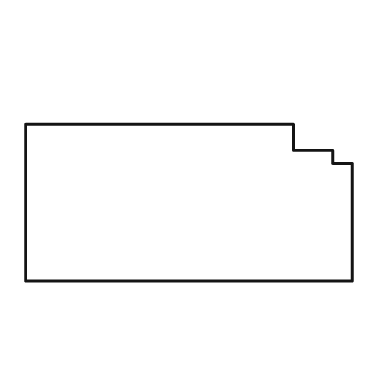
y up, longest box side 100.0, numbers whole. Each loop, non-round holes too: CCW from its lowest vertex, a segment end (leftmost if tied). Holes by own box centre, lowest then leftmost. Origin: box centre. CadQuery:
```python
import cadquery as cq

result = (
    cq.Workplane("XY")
    .moveTo(-50.0, -24.0)
    .lineTo(50.0, -24.0)
    .lineTo(50.0, 12.0)
    .lineTo(44.0, 12.0)
    .lineTo(44.0, 16.0)
    .lineTo(32.0, 16.0)
    .lineTo(32.0, 24.0)
    .lineTo(-50.0, 24.0)
    .close()
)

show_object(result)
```